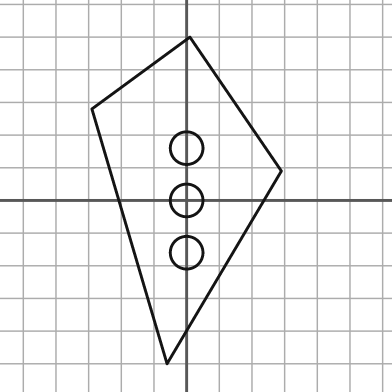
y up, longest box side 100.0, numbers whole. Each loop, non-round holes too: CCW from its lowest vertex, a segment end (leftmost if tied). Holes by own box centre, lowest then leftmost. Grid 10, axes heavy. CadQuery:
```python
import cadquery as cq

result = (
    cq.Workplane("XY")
    .moveTo(-6.0, -50.0)
    .lineTo(29.0, 9.0)
    .lineTo(1.0, 50.0)
    .lineTo(-29.0, 28.0)
    .close()
    .moveTo(0.0, -16.0)
    .circle(5.0)
    .moveTo(0.0, 0.0)
    .circle(5.0)
    .moveTo(0.0, 16.0)
    .circle(5.0)
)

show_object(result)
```